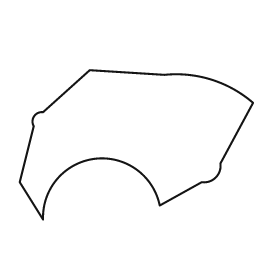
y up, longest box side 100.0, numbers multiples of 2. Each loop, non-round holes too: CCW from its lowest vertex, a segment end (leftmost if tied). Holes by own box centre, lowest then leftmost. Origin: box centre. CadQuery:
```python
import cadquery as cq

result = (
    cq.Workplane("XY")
    .moveTo(-40.0, -32.0)
    .threePointArc((-18.0, -6.0), (10.0, -26.0))
    .lineTo(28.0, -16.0)
    .threePointArc((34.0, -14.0), (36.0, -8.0))
    .lineTo(50.0, 18.0)
    .threePointArc((32.0, 28.0), (12.0, 30.0))
    .lineTo(-20.0, 32.0)
    .lineTo(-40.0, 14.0)
    .threePointArc((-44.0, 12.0), (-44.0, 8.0))
    .lineTo(-50.0, -16.0)
    .close()
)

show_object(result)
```